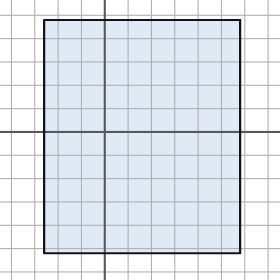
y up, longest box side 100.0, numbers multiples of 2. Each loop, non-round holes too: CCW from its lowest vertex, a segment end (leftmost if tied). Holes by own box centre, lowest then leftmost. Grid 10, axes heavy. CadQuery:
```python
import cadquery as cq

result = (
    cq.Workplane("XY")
    .moveTo(-26.0, -52.0)
    .lineTo(58.0, -52.0)
    .lineTo(58.0, 48.0)
    .lineTo(-26.0, 48.0)
    .close()
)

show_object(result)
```